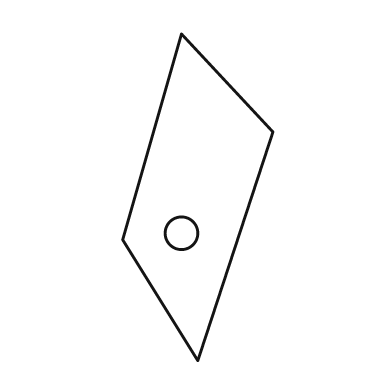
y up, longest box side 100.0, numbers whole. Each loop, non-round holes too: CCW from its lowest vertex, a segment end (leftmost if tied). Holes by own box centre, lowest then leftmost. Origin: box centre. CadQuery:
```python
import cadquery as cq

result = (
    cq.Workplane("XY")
    .moveTo(0.0, -50.0)
    .lineTo(23.0, 20.0)
    .lineTo(-5.0, 50.0)
    .lineTo(-23.0, -13.0)
    .close()
    .moveTo(-5.0, -11.0)
    .circle(5.0)
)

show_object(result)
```